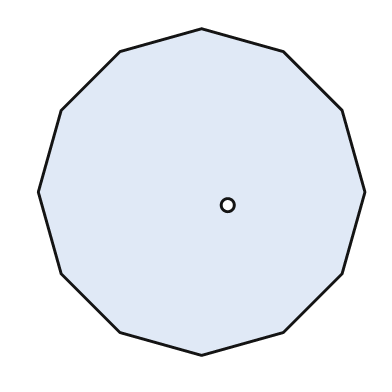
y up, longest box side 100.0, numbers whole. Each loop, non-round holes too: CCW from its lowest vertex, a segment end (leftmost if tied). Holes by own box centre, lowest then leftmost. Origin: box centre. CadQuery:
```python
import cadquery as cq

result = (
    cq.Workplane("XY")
    .moveTo(0.0, -50.0)
    .lineTo(25.0, -43.0)
    .lineTo(43.0, -25.0)
    .lineTo(50.0, 0.0)
    .lineTo(43.0, 25.0)
    .lineTo(25.0, 43.0)
    .lineTo(0.0, 50.0)
    .lineTo(-25.0, 43.0)
    .lineTo(-43.0, 25.0)
    .lineTo(-50.0, 0.0)
    .lineTo(-43.0, -25.0)
    .lineTo(-25.0, -43.0)
    .close()
    .moveTo(8.0, -4.0)
    .circle(2.0)
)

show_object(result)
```